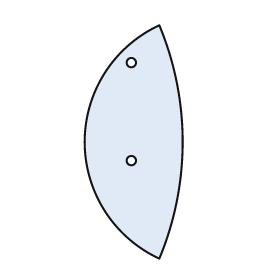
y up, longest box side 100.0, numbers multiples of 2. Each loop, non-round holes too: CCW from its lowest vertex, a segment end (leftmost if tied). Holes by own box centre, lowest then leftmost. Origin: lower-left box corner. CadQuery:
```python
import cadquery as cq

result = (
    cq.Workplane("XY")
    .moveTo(32.0, 0.0)
    .threePointArc((42.0, 50.0), (32.0, 100.0))
    .threePointArc((0.0, 50.0), (32.0, 0.0))
    .close()
    .moveTo(20.0, 42.0)
    .circle(2.0)
    .moveTo(20.0, 84.0)
    .circle(2.0)
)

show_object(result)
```